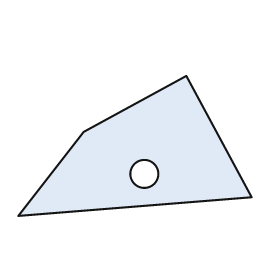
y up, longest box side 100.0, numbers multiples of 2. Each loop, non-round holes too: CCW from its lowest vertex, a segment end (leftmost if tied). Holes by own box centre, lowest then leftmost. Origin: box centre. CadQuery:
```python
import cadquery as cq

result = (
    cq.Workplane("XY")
    .moveTo(-50.0, -30.0)
    .lineTo(50.0, -22.0)
    .lineTo(22.0, 30.0)
    .lineTo(-22.0, 6.0)
    .close()
    .moveTo(4.0, -12.0)
    .circle(6.0)
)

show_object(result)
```